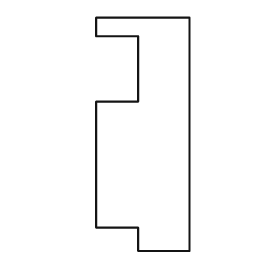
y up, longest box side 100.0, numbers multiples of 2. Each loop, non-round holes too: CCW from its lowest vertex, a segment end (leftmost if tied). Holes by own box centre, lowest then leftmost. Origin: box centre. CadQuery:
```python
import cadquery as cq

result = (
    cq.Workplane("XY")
    .moveTo(-2.0, -50.0)
    .lineTo(20.0, -50.0)
    .lineTo(20.0, 50.0)
    .lineTo(-20.0, 50.0)
    .lineTo(-20.0, 42.0)
    .lineTo(-2.0, 42.0)
    .lineTo(-2.0, 14.0)
    .lineTo(-20.0, 14.0)
    .lineTo(-20.0, -40.0)
    .lineTo(-2.0, -40.0)
    .close()
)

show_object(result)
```